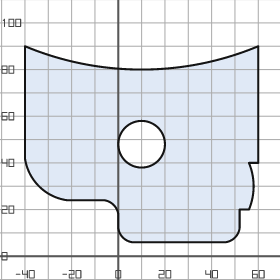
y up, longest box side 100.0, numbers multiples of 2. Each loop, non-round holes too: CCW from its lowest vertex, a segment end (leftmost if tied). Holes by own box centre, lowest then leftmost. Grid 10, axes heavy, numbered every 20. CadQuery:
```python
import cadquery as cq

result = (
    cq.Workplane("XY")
    .moveTo(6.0, 6.0)
    .lineTo(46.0, 6.0)
    .threePointArc((50.0, 8.0), (52.0, 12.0))
    .lineTo(52.0, 20.0)
    .lineTo(56.0, 20.0)
    .threePointArc((58.0, 30.0), (56.0, 40.0))
    .lineTo(60.0, 40.0)
    .lineTo(60.0, 90.0)
    .threePointArc((10.0, 80.0), (-40.0, 90.0))
    .lineTo(-40.0, 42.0)
    .threePointArc((-34.0, 30.0), (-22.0, 24.0))
    .lineTo(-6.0, 24.0)
    .threePointArc((-2.0, 22.0), (0.0, 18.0))
    .lineTo(0.0, 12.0)
    .threePointArc((2.0, 8.0), (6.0, 6.0))
    .close()
    .moveTo(10.0, 48.0)
    .circle(10.0)
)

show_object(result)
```